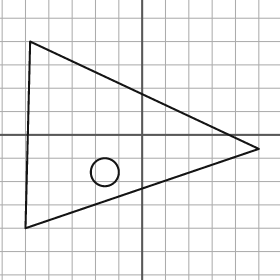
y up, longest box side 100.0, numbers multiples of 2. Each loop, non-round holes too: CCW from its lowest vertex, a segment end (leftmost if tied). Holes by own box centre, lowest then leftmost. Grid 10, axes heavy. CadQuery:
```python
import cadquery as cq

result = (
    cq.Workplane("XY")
    .moveTo(-50.0, -40.0)
    .lineTo(50.0, -6.0)
    .lineTo(-48.0, 40.0)
    .close()
    .moveTo(-16.0, -16.0)
    .circle(6.0)
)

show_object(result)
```